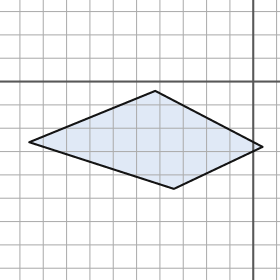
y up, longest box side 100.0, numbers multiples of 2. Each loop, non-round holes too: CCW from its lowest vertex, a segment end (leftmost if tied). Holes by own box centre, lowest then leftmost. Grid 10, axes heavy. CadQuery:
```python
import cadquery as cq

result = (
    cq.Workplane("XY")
    .moveTo(-34.0, -46.0)
    .lineTo(4.0, -28.0)
    .lineTo(-42.0, -4.0)
    .lineTo(-96.0, -26.0)
    .close()
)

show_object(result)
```